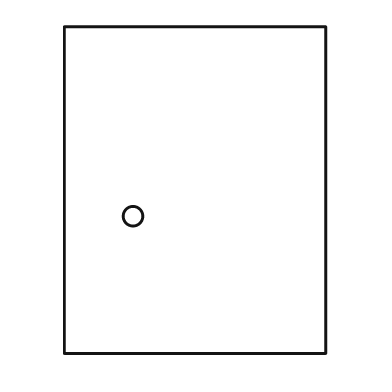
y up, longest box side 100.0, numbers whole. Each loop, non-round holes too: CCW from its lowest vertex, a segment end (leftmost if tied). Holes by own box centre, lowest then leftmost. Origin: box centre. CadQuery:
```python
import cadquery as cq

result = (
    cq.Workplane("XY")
    .moveTo(-40.0, -50.0)
    .lineTo(40.0, -50.0)
    .lineTo(40.0, 50.0)
    .lineTo(-40.0, 50.0)
    .close()
    .moveTo(-19.0, -8.0)
    .circle(3.0)
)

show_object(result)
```